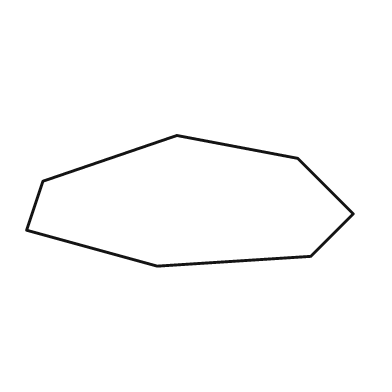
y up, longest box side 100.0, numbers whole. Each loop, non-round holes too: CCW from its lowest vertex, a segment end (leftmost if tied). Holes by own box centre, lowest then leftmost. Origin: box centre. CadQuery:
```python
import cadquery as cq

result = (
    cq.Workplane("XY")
    .moveTo(-10.0, -20.0)
    .lineTo(37.0, -17.0)
    .lineTo(50.0, -4.0)
    .lineTo(33.0, 13.0)
    .lineTo(-4.0, 20.0)
    .lineTo(-45.0, 6.0)
    .lineTo(-50.0, -9.0)
    .close()
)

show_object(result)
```